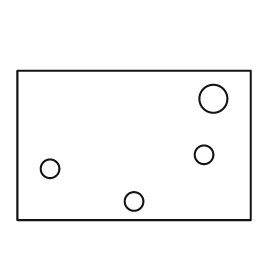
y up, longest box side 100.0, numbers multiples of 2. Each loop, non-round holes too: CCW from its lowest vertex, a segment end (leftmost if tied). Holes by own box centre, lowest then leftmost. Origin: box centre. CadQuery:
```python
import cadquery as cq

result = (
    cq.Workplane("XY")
    .moveTo(-50.0, -32.0)
    .lineTo(50.0, -32.0)
    .lineTo(50.0, 32.0)
    .lineTo(-50.0, 32.0)
    .close()
    .moveTo(0.0, -24.0)
    .circle(4.0)
    .moveTo(-36.0, -10.0)
    .circle(4.0)
    .moveTo(30.0, -4.0)
    .circle(4.0)
    .moveTo(34.0, 20.0)
    .circle(6.0)
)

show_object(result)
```